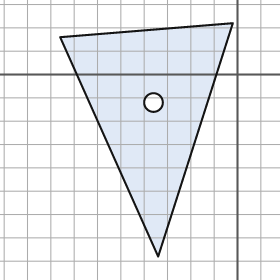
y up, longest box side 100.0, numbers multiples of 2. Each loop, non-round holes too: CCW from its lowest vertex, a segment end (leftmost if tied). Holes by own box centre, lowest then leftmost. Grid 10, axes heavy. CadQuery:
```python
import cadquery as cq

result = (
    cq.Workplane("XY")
    .moveTo(-34.0, -78.0)
    .lineTo(-2.0, 22.0)
    .lineTo(-76.0, 16.0)
    .close()
    .moveTo(-36.0, -12.0)
    .circle(4.0)
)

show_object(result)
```